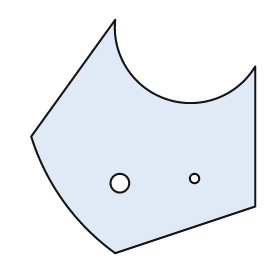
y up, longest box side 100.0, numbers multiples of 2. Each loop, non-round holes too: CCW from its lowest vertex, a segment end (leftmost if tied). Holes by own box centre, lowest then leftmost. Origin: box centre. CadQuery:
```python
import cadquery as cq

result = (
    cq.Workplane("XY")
    .moveTo(-12.0, -50.0)
    .lineTo(48.0, -30.0)
    .lineTo(48.0, 30.0)
    .threePointArc((10.0, 16.0), (-12.0, 50.0))
    .lineTo(-48.0, 0.0)
    .threePointArc((-34.0, -28.0), (-12.0, -50.0))
    .close()
    .moveTo(-10.0, -20.0)
    .circle(4.0)
    .moveTo(22.0, -18.0)
    .circle(2.0)
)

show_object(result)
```